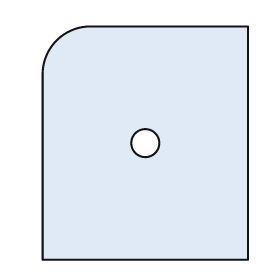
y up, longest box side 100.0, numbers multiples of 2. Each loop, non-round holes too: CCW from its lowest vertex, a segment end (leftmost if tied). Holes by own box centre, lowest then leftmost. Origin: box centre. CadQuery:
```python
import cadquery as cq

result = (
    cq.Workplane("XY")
    .moveTo(-44.0, -50.0)
    .lineTo(44.0, -50.0)
    .lineTo(44.0, 50.0)
    .lineTo(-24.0, 50.0)
    .threePointArc((-38.0, 44.0), (-44.0, 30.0))
    .close()
    .moveTo(0.0, 0.0)
    .circle(6.0)
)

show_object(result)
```